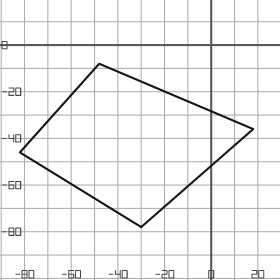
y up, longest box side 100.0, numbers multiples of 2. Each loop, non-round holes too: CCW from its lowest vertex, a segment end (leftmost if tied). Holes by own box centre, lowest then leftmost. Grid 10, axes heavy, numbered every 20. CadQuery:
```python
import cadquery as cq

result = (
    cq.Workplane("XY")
    .moveTo(-30.0, -78.0)
    .lineTo(18.0, -36.0)
    .lineTo(-48.0, -8.0)
    .lineTo(-82.0, -46.0)
    .close()
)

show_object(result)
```